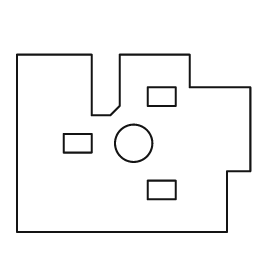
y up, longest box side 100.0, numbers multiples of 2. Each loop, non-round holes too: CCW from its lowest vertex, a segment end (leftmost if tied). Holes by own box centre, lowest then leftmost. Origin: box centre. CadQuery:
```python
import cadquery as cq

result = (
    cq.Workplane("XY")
    .moveTo(-50.0, -38.0)
    .lineTo(40.0, -38.0)
    .lineTo(40.0, -12.0)
    .lineTo(50.0, -12.0)
    .lineTo(50.0, 24.0)
    .lineTo(24.0, 24.0)
    .lineTo(24.0, 38.0)
    .lineTo(-6.0, 38.0)
    .lineTo(-6.0, 16.0)
    .lineTo(-10.0, 12.0)
    .lineTo(-18.0, 12.0)
    .lineTo(-18.0, 38.0)
    .lineTo(-50.0, 38.0)
    .close()
    .moveTo(6.0, -24.0)
    .lineTo(18.0, -24.0)
    .lineTo(18.0, -16.0)
    .lineTo(6.0, -16.0)
    .close()
    .moveTo(-30.0, -4.0)
    .lineTo(-18.0, -4.0)
    .lineTo(-18.0, 4.0)
    .lineTo(-30.0, 4.0)
    .close()
    .moveTo(0.0, 0.0)
    .circle(8.0)
    .moveTo(6.0, 16.0)
    .lineTo(18.0, 16.0)
    .lineTo(18.0, 24.0)
    .lineTo(6.0, 24.0)
    .close()
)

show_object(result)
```